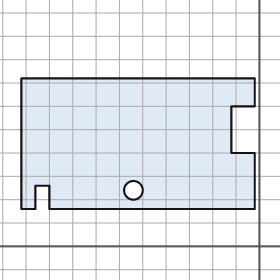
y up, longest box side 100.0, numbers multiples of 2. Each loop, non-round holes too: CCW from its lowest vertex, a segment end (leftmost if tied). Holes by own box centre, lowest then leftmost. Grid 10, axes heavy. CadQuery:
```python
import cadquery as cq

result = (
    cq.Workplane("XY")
    .moveTo(-102.0, 16.0)
    .lineTo(-96.0, 16.0)
    .lineTo(-96.0, 26.0)
    .lineTo(-90.0, 26.0)
    .lineTo(-90.0, 16.0)
    .lineTo(-2.0, 16.0)
    .lineTo(-2.0, 40.0)
    .lineTo(-12.0, 40.0)
    .lineTo(-12.0, 60.0)
    .lineTo(-2.0, 60.0)
    .lineTo(-2.0, 72.0)
    .lineTo(-102.0, 72.0)
    .close()
    .moveTo(-54.0, 24.0)
    .circle(4.0)
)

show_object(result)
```